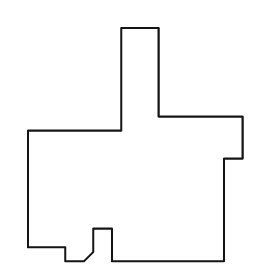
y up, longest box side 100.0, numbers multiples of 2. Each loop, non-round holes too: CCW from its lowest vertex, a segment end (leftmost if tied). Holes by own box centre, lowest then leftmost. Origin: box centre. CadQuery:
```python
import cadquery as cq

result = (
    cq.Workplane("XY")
    .moveTo(-30.0, -50.0)
    .lineTo(-22.0, -50.0)
    .lineTo(-18.0, -46.0)
    .lineTo(-18.0, -36.0)
    .lineTo(-10.0, -36.0)
    .lineTo(-10.0, -50.0)
    .lineTo(38.0, -50.0)
    .lineTo(38.0, -6.0)
    .lineTo(46.0, -6.0)
    .lineTo(46.0, 12.0)
    .lineTo(10.0, 12.0)
    .lineTo(10.0, 50.0)
    .lineTo(-6.0, 50.0)
    .lineTo(-6.0, 6.0)
    .lineTo(-46.0, 6.0)
    .lineTo(-46.0, -44.0)
    .lineTo(-30.0, -44.0)
    .close()
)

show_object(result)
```